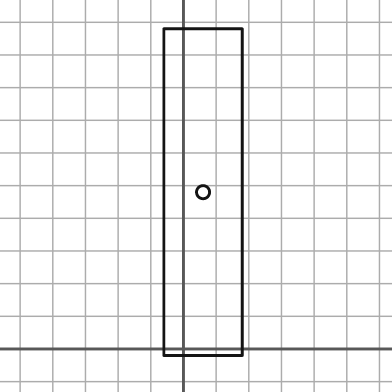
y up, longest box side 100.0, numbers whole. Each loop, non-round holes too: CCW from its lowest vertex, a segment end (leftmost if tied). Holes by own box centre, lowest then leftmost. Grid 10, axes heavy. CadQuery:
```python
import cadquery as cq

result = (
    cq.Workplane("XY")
    .moveTo(-6.0, -2.0)
    .lineTo(18.0, -2.0)
    .lineTo(18.0, 98.0)
    .lineTo(-6.0, 98.0)
    .close()
    .moveTo(6.0, 48.0)
    .circle(2.0)
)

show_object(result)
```